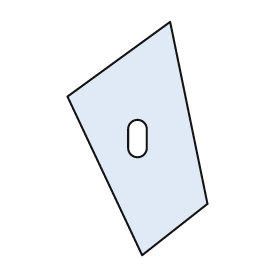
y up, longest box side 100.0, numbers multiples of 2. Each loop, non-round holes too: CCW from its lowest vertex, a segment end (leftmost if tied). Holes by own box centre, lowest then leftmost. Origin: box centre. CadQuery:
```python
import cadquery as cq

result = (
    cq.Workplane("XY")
    .moveTo(2.0, -50.0)
    .lineTo(30.0, -28.0)
    .lineTo(14.0, 50.0)
    .lineTo(-30.0, 18.0)
    .close()
    .moveTo(-4.0, -4.0)
    .threePointArc((0.0, -8.0), (4.0, -4.0))
    .lineTo(4.0, 4.0)
    .threePointArc((0.0, 8.0), (-4.0, 4.0))
    .close()
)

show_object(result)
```